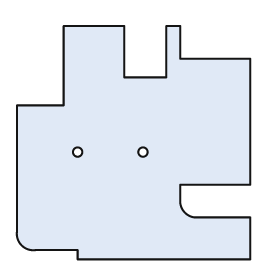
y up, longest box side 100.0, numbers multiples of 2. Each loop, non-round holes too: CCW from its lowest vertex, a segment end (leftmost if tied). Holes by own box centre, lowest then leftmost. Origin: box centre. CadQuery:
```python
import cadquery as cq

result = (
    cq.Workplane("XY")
    .moveTo(-24.0, -50.0)
    .lineTo(50.0, -50.0)
    .lineTo(50.0, -32.0)
    .lineTo(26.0, -32.0)
    .threePointArc((22.0, -30.0), (20.0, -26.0))
    .lineTo(20.0, -18.0)
    .lineTo(50.0, -18.0)
    .lineTo(50.0, 36.0)
    .lineTo(20.0, 36.0)
    .lineTo(20.0, 50.0)
    .lineTo(14.0, 50.0)
    .lineTo(14.0, 28.0)
    .lineTo(-4.0, 28.0)
    .lineTo(-4.0, 50.0)
    .lineTo(-30.0, 50.0)
    .lineTo(-30.0, 16.0)
    .lineTo(-50.0, 16.0)
    .lineTo(-50.0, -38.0)
    .threePointArc((-48.0, -44.0), (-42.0, -46.0))
    .lineTo(-24.0, -46.0)
    .close()
    .moveTo(-24.0, -4.0)
    .circle(2.0)
    .moveTo(4.0, -4.0)
    .circle(2.0)
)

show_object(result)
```